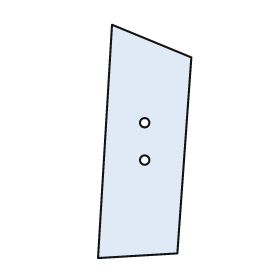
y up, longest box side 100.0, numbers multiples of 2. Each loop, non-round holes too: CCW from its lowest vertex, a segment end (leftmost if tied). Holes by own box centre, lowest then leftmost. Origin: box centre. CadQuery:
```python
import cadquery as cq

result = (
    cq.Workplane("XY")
    .moveTo(-20.0, -50.0)
    .lineTo(14.0, -48.0)
    .lineTo(20.0, 36.0)
    .lineTo(-14.0, 50.0)
    .close()
    .moveTo(0.0, -8.0)
    .circle(2.0)
    .moveTo(0.0, 8.0)
    .circle(2.0)
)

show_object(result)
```